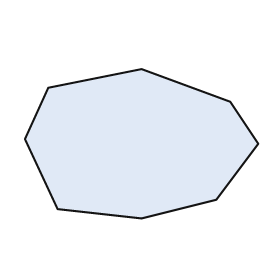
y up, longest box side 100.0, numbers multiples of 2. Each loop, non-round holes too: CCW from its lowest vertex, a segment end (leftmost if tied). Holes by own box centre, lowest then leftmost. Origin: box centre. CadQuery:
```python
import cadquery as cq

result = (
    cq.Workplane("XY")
    .moveTo(0.0, -32.0)
    .lineTo(32.0, -24.0)
    .lineTo(50.0, 0.0)
    .lineTo(38.0, 18.0)
    .lineTo(0.0, 32.0)
    .lineTo(-40.0, 24.0)
    .lineTo(-50.0, 2.0)
    .lineTo(-36.0, -28.0)
    .close()
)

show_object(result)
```